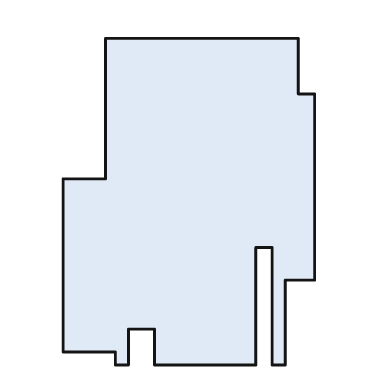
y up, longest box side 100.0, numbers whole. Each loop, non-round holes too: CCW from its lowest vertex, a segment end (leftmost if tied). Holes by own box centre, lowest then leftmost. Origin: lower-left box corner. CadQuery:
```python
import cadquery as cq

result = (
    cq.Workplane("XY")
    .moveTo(16.0, 0.0)
    .lineTo(20.0, 0.0)
    .lineTo(20.0, 11.0)
    .lineTo(28.0, 11.0)
    .lineTo(28.0, 0.0)
    .lineTo(59.0, 0.0)
    .lineTo(59.0, 36.0)
    .lineTo(64.0, 36.0)
    .lineTo(64.0, 0.0)
    .lineTo(68.0, 0.0)
    .lineTo(68.0, 26.0)
    .lineTo(77.0, 26.0)
    .lineTo(77.0, 83.0)
    .lineTo(72.0, 83.0)
    .lineTo(72.0, 100.0)
    .lineTo(13.0, 100.0)
    .lineTo(13.0, 57.0)
    .lineTo(0.0, 57.0)
    .lineTo(0.0, 4.0)
    .lineTo(16.0, 4.0)
    .close()
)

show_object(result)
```